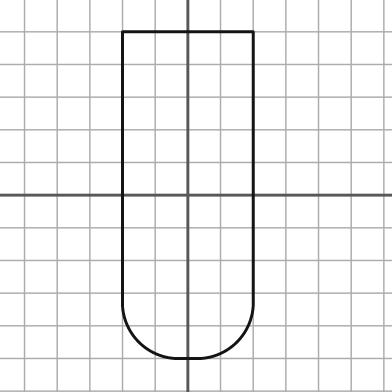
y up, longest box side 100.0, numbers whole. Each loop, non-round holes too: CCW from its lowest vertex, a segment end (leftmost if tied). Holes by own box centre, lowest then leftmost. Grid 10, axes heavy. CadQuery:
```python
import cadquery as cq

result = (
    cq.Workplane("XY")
    .moveTo(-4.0, -50.0)
    .lineTo(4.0, -50.0)
    .threePointArc((15.0, -45.0), (20.0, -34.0))
    .lineTo(20.0, 50.0)
    .lineTo(-20.0, 50.0)
    .lineTo(-20.0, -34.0)
    .threePointArc((-15.0, -45.0), (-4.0, -50.0))
    .close()
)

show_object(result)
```